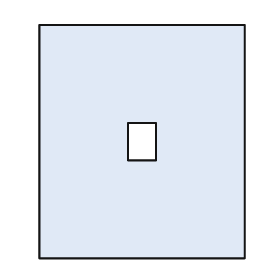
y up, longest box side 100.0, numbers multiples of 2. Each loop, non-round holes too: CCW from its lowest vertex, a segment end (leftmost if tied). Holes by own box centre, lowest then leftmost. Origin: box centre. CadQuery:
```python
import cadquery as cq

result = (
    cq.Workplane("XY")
    .moveTo(-44.0, -50.0)
    .lineTo(44.0, -50.0)
    .lineTo(44.0, 50.0)
    .lineTo(-44.0, 50.0)
    .close()
    .moveTo(-6.0, -8.0)
    .lineTo(6.0, -8.0)
    .lineTo(6.0, 8.0)
    .lineTo(-6.0, 8.0)
    .close()
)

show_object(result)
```